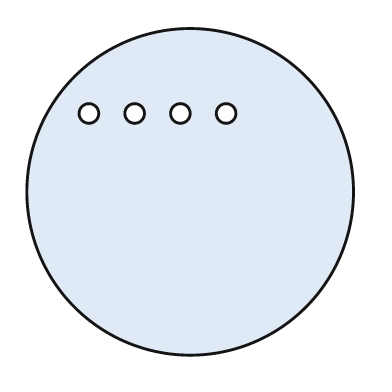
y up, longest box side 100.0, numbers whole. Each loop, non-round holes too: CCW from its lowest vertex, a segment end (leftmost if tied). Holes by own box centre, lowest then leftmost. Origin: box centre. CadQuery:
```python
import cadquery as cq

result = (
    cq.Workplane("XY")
    .moveTo(0.0, 0.0)
    .circle(50.0)
    .moveTo(-31.0, 24.0)
    .circle(3.0)
    .moveTo(-17.0, 24.0)
    .circle(3.0)
    .moveTo(-3.0, 24.0)
    .circle(3.0)
    .moveTo(11.0, 24.0)
    .circle(3.0)
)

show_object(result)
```